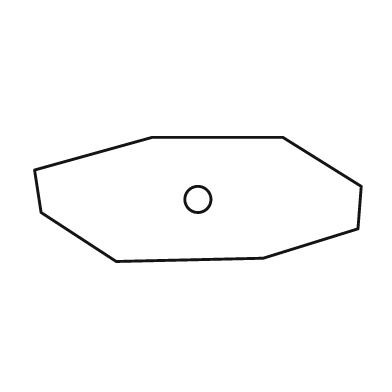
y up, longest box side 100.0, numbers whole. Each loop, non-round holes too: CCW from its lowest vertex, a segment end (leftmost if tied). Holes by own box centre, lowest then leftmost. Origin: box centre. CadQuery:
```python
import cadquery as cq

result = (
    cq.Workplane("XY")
    .moveTo(-25.0, -19.0)
    .lineTo(20.0, -18.0)
    .lineTo(49.0, -9.0)
    .lineTo(50.0, 4.0)
    .lineTo(26.0, 19.0)
    .lineTo(-14.0, 19.0)
    .lineTo(-50.0, 9.0)
    .lineTo(-48.0, -4.0)
    .close()
    .moveTo(0.0, 0.0)
    .circle(4.0)
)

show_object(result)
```